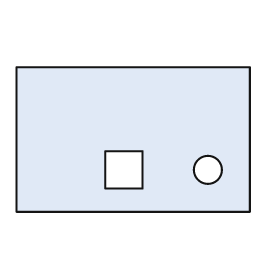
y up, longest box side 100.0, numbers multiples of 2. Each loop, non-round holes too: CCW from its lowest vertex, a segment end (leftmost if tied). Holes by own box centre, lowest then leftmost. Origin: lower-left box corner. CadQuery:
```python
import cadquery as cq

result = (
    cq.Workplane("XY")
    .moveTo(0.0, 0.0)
    .lineTo(100.0, 0.0)
    .lineTo(100.0, 62.0)
    .lineTo(0.0, 62.0)
    .close()
    .moveTo(38.0, 10.0)
    .lineTo(54.0, 10.0)
    .lineTo(54.0, 26.0)
    .lineTo(38.0, 26.0)
    .close()
    .moveTo(82.0, 18.0)
    .circle(6.0)
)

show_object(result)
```